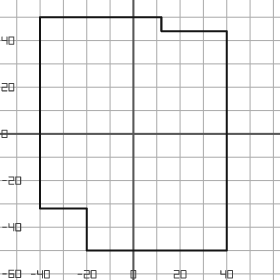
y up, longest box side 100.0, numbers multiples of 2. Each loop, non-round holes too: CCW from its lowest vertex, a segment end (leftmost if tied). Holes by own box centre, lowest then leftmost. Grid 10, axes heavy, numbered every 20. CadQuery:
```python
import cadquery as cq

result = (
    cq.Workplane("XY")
    .moveTo(-20.0, -50.0)
    .lineTo(40.0, -50.0)
    .lineTo(40.0, 44.0)
    .lineTo(12.0, 44.0)
    .lineTo(12.0, 50.0)
    .lineTo(-40.0, 50.0)
    .lineTo(-40.0, -32.0)
    .lineTo(-20.0, -32.0)
    .close()
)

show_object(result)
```